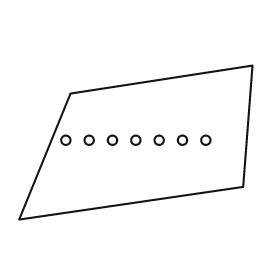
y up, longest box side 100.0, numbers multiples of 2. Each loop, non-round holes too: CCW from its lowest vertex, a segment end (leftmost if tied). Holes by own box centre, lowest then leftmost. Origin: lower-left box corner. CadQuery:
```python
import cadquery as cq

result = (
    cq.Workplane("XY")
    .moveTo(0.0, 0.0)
    .lineTo(96.0, 14.0)
    .lineTo(100.0, 66.0)
    .lineTo(22.0, 54.0)
    .close()
    .moveTo(20.0, 34.0)
    .circle(2.0)
    .moveTo(30.0, 34.0)
    .circle(2.0)
    .moveTo(40.0, 34.0)
    .circle(2.0)
    .moveTo(50.0, 34.0)
    .circle(2.0)
    .moveTo(60.0, 34.0)
    .circle(2.0)
    .moveTo(70.0, 34.0)
    .circle(2.0)
    .moveTo(80.0, 34.0)
    .circle(2.0)
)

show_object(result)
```